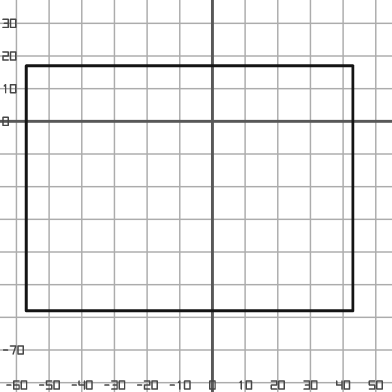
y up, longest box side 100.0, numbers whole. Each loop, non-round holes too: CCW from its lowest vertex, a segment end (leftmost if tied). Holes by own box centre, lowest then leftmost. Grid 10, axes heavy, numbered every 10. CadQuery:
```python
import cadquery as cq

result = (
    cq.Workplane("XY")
    .moveTo(-57.0, -58.0)
    .lineTo(43.0, -58.0)
    .lineTo(43.0, 17.0)
    .lineTo(-57.0, 17.0)
    .close()
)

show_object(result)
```